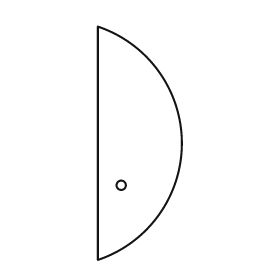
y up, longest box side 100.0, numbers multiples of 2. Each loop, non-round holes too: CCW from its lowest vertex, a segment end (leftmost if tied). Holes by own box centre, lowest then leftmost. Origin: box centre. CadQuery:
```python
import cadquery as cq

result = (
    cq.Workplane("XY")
    .moveTo(-18.0, -50.0)
    .threePointArc((18.0, 0.0), (-18.0, 50.0))
    .close()
    .moveTo(-8.0, -18.0)
    .circle(2.0)
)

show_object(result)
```